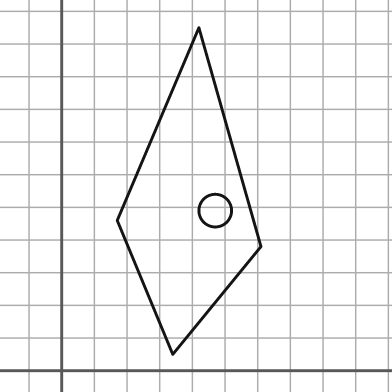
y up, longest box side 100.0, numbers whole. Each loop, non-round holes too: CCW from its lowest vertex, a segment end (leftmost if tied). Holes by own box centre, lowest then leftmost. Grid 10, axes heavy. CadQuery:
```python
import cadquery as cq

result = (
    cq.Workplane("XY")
    .moveTo(34.0, 5.0)
    .lineTo(61.0, 38.0)
    .lineTo(42.0, 105.0)
    .lineTo(17.0, 46.0)
    .close()
    .moveTo(47.0, 49.0)
    .circle(5.0)
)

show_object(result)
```